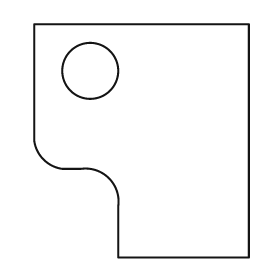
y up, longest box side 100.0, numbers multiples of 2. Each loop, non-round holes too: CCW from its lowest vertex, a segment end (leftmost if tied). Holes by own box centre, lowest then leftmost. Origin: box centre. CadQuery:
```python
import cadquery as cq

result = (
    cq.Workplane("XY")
    .moveTo(-10.0, -50.0)
    .lineTo(46.0, -50.0)
    .lineTo(46.0, 50.0)
    .lineTo(-46.0, 50.0)
    .lineTo(-46.0, 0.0)
    .threePointArc((-42.0, -8.0), (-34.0, -12.0))
    .lineTo(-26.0, -12.0)
    .threePointArc((-14.0, -16.0), (-10.0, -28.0))
    .close()
    .moveTo(-22.0, 30.0)
    .circle(12.0)
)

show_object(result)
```